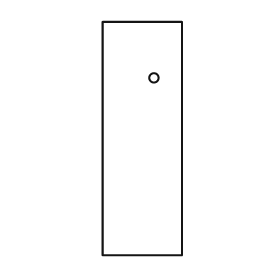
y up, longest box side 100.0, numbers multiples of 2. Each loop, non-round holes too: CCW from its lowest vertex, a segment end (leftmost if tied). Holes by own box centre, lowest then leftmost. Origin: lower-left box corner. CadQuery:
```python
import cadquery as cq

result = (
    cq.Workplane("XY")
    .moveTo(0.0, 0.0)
    .lineTo(34.0, 0.0)
    .lineTo(34.0, 100.0)
    .lineTo(0.0, 100.0)
    .close()
    .moveTo(22.0, 76.0)
    .circle(2.0)
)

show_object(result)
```